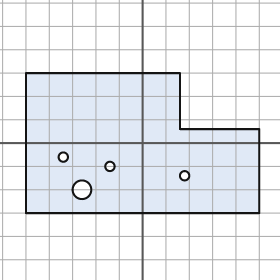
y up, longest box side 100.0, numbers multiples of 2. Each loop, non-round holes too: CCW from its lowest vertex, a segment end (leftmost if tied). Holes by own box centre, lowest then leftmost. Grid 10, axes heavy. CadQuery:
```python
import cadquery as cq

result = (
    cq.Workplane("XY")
    .moveTo(-50.0, -30.0)
    .lineTo(50.0, -30.0)
    .lineTo(50.0, 6.0)
    .lineTo(16.0, 6.0)
    .lineTo(16.0, 30.0)
    .lineTo(-50.0, 30.0)
    .close()
    .moveTo(-26.0, -20.0)
    .circle(4.0)
    .moveTo(18.0, -14.0)
    .circle(2.0)
    .moveTo(-14.0, -10.0)
    .circle(2.0)
    .moveTo(-34.0, -6.0)
    .circle(2.0)
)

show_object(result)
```